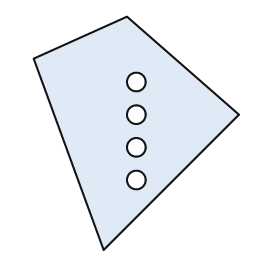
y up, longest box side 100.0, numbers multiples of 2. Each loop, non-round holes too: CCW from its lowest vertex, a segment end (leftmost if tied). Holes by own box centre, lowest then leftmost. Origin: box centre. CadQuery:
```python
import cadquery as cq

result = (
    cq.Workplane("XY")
    .moveTo(-14.0, -50.0)
    .lineTo(44.0, 8.0)
    .lineTo(-4.0, 50.0)
    .lineTo(-44.0, 32.0)
    .close()
    .moveTo(0.0, -20.0)
    .circle(4.0)
    .moveTo(0.0, -6.0)
    .circle(4.0)
    .moveTo(0.0, 8.0)
    .circle(4.0)
    .moveTo(0.0, 22.0)
    .circle(4.0)
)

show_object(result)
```